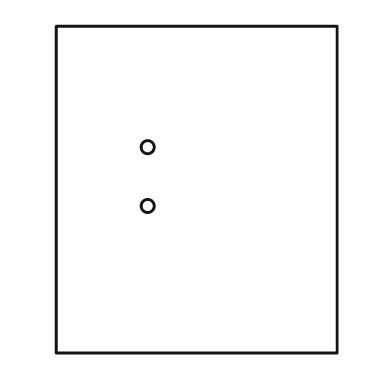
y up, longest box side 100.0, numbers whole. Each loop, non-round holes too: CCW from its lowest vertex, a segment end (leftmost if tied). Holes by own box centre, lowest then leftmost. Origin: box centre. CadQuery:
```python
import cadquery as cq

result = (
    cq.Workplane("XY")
    .moveTo(-43.0, -50.0)
    .lineTo(43.0, -50.0)
    .lineTo(43.0, 50.0)
    .lineTo(-43.0, 50.0)
    .close()
    .moveTo(-15.0, -5.0)
    .circle(2.0)
    .moveTo(-15.0, 13.0)
    .circle(2.0)
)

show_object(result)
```